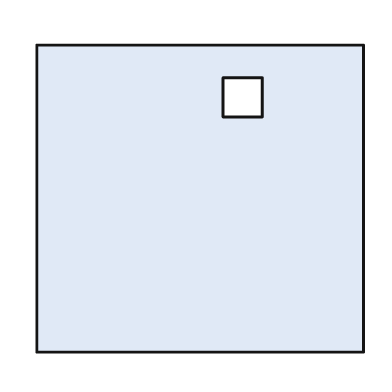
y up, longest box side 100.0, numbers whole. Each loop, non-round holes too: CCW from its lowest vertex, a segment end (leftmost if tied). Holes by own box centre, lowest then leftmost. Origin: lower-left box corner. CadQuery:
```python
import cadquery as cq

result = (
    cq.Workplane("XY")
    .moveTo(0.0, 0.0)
    .lineTo(100.0, 0.0)
    .lineTo(100.0, 94.0)
    .lineTo(0.0, 94.0)
    .close()
    .moveTo(57.0, 72.0)
    .lineTo(69.0, 72.0)
    .lineTo(69.0, 84.0)
    .lineTo(57.0, 84.0)
    .close()
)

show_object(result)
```